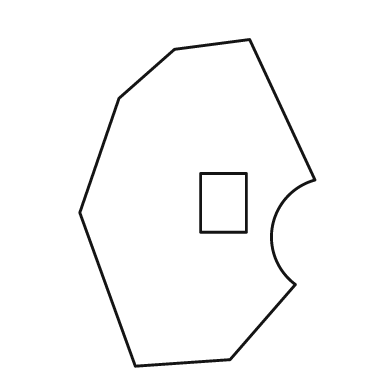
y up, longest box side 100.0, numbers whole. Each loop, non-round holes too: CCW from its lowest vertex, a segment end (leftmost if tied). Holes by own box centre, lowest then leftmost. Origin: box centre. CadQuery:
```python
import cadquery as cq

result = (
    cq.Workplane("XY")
    .moveTo(-19.0, -50.0)
    .lineTo(10.0, -48.0)
    .lineTo(30.0, -25.0)
    .threePointArc((23.0, -7.0), (36.0, 7.0))
    .lineTo(16.0, 50.0)
    .lineTo(-7.0, 47.0)
    .lineTo(-24.0, 32.0)
    .lineTo(-36.0, -3.0)
    .close()
    .moveTo(1.0, -9.0)
    .lineTo(15.0, -9.0)
    .lineTo(15.0, 9.0)
    .lineTo(1.0, 9.0)
    .close()
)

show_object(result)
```